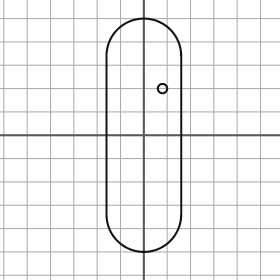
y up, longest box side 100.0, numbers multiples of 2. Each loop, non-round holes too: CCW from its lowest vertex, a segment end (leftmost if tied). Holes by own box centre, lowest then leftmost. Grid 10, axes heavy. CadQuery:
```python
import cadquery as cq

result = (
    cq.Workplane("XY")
    .moveTo(-16.0, -34.0)
    .threePointArc((0.0, -50.0), (16.0, -34.0))
    .lineTo(16.0, 34.0)
    .threePointArc((0.0, 50.0), (-16.0, 34.0))
    .close()
    .moveTo(8.0, 20.0)
    .circle(2.0)
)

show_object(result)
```